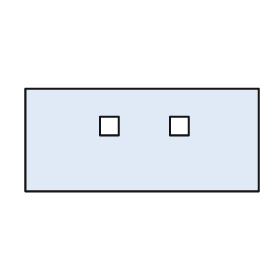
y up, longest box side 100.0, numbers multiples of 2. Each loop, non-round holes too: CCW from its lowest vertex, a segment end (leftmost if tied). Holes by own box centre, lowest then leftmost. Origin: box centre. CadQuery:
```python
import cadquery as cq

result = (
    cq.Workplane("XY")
    .moveTo(-50.0, -22.0)
    .lineTo(50.0, -22.0)
    .lineTo(50.0, 22.0)
    .lineTo(-50.0, 22.0)
    .close()
    .moveTo(-18.0, 2.0)
    .lineTo(-10.0, 2.0)
    .lineTo(-10.0, 10.0)
    .lineTo(-18.0, 10.0)
    .close()
    .moveTo(12.0, 2.0)
    .lineTo(20.0, 2.0)
    .lineTo(20.0, 10.0)
    .lineTo(12.0, 10.0)
    .close()
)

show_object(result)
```